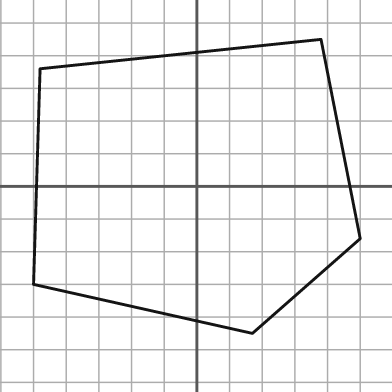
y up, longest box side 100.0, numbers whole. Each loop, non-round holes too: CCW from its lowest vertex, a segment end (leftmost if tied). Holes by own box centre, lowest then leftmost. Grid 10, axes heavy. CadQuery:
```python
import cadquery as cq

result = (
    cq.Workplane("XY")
    .moveTo(17.0, -45.0)
    .lineTo(50.0, -16.0)
    .lineTo(38.0, 45.0)
    .lineTo(-48.0, 36.0)
    .lineTo(-50.0, -30.0)
    .close()
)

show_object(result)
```